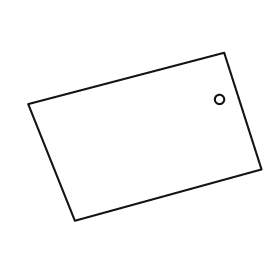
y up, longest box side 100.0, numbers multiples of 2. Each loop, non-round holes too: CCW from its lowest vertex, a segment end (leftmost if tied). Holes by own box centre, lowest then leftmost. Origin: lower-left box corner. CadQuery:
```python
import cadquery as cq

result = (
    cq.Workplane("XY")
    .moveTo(20.0, 0.0)
    .lineTo(100.0, 22.0)
    .lineTo(84.0, 72.0)
    .lineTo(0.0, 50.0)
    .close()
    .moveTo(82.0, 52.0)
    .circle(2.0)
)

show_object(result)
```